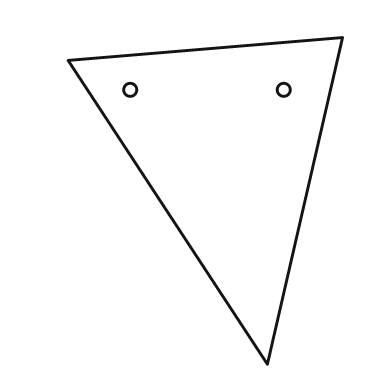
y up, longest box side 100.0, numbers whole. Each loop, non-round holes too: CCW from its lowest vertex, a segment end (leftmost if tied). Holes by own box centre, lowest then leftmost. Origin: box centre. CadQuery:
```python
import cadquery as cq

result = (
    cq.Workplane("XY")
    .moveTo(19.0, -50.0)
    .lineTo(42.0, 50.0)
    .lineTo(-42.0, 43.0)
    .close()
    .moveTo(-23.0, 34.0)
    .circle(2.0)
    .moveTo(24.0, 34.0)
    .circle(2.0)
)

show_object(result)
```